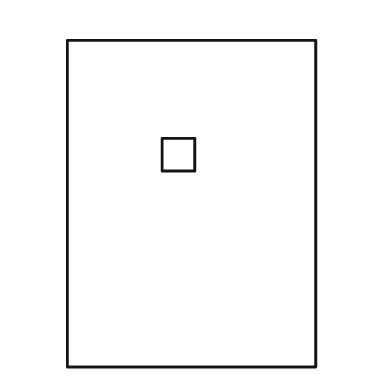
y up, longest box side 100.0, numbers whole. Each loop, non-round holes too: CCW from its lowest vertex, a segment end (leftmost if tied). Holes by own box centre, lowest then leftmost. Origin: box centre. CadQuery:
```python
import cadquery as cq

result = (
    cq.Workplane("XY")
    .moveTo(-38.0, -50.0)
    .lineTo(38.0, -50.0)
    .lineTo(38.0, 50.0)
    .lineTo(-38.0, 50.0)
    .close()
    .moveTo(-9.0, 10.0)
    .lineTo(1.0, 10.0)
    .lineTo(1.0, 20.0)
    .lineTo(-9.0, 20.0)
    .close()
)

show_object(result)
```